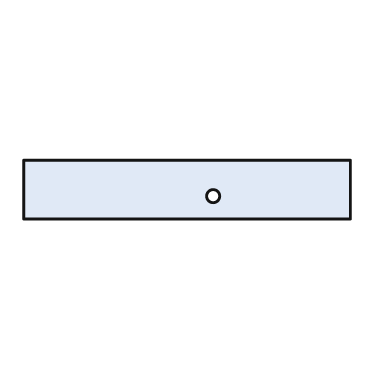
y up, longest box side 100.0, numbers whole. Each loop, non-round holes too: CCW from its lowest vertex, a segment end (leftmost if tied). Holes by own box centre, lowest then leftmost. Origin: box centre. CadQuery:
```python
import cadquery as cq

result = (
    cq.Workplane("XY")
    .moveTo(-50.0, -9.0)
    .lineTo(50.0, -9.0)
    .lineTo(50.0, 9.0)
    .lineTo(-50.0, 9.0)
    .close()
    .moveTo(8.0, -2.0)
    .circle(2.0)
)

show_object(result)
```